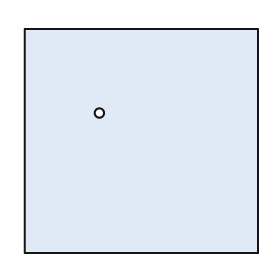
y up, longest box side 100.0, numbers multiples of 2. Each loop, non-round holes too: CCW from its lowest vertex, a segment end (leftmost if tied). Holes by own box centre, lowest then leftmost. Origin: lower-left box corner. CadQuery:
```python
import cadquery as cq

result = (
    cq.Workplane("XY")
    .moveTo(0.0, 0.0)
    .lineTo(100.0, 0.0)
    .lineTo(100.0, 96.0)
    .lineTo(0.0, 96.0)
    .close()
    .moveTo(32.0, 60.0)
    .circle(2.0)
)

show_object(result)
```